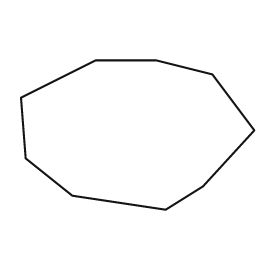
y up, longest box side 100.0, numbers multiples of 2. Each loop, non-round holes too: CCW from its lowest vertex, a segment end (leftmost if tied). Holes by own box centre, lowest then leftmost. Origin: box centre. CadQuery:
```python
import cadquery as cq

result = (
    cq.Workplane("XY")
    .moveTo(12.0, -32.0)
    .lineTo(28.0, -22.0)
    .lineTo(50.0, 2.0)
    .lineTo(32.0, 26.0)
    .lineTo(8.0, 32.0)
    .lineTo(-18.0, 32.0)
    .lineTo(-50.0, 16.0)
    .lineTo(-48.0, -10.0)
    .lineTo(-28.0, -26.0)
    .close()
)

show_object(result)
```